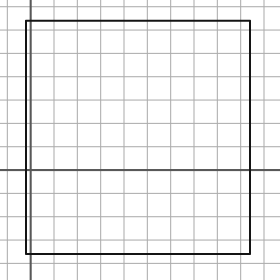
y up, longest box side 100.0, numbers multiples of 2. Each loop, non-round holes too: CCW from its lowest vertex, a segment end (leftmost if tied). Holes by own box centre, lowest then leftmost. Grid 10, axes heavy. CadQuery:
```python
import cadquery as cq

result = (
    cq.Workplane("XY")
    .moveTo(-2.0, -36.0)
    .lineTo(94.0, -36.0)
    .lineTo(94.0, 64.0)
    .lineTo(-2.0, 64.0)
    .close()
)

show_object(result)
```